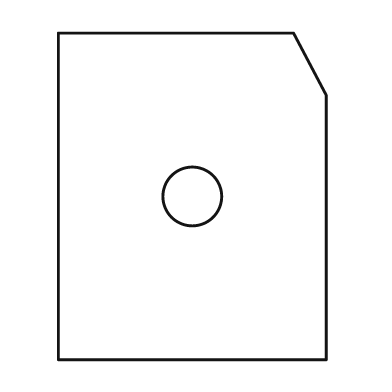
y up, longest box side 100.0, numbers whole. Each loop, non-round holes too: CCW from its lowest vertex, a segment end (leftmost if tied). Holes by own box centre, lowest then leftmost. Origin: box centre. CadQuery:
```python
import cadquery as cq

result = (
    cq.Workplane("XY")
    .moveTo(-41.0, -50.0)
    .lineTo(41.0, -50.0)
    .lineTo(41.0, 31.0)
    .lineTo(31.0, 50.0)
    .lineTo(-41.0, 50.0)
    .close()
    .moveTo(0.0, 0.0)
    .circle(9.0)
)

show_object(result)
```